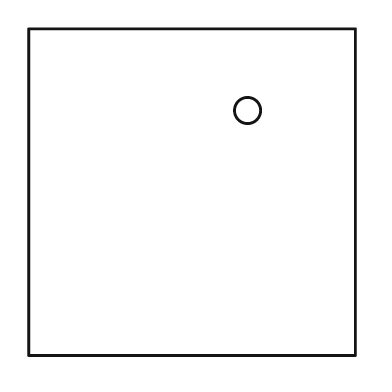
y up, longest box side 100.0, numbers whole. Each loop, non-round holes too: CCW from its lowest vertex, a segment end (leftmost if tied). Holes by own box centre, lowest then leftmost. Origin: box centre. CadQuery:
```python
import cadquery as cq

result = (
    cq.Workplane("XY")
    .moveTo(-50.0, -50.0)
    .lineTo(50.0, -50.0)
    .lineTo(50.0, 50.0)
    .lineTo(-50.0, 50.0)
    .close()
    .moveTo(17.0, 25.0)
    .circle(4.0)
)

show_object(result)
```